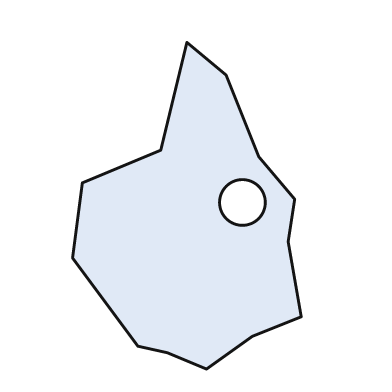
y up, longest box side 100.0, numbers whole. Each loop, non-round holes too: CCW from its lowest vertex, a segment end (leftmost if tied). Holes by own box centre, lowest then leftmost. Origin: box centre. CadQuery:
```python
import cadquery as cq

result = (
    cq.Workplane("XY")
    .moveTo(6.0, -50.0)
    .lineTo(20.0, -40.0)
    .lineTo(35.0, -34.0)
    .lineTo(31.0, -11.0)
    .lineTo(33.0, 2.0)
    .lineTo(22.0, 15.0)
    .lineTo(12.0, 40.0)
    .lineTo(0.0, 50.0)
    .lineTo(-8.0, 17.0)
    .lineTo(-32.0, 7.0)
    .lineTo(-35.0, -16.0)
    .lineTo(-15.0, -43.0)
    .lineTo(-6.0, -45.0)
    .close()
    .moveTo(17.0, 1.0)
    .circle(7.0)
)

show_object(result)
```